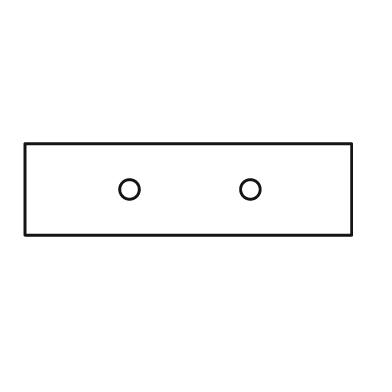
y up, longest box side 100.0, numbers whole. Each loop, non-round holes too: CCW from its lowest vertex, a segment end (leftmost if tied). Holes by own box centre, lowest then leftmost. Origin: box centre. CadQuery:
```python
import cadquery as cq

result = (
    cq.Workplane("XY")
    .moveTo(-50.0, -14.0)
    .lineTo(50.0, -14.0)
    .lineTo(50.0, 14.0)
    .lineTo(-50.0, 14.0)
    .close()
    .moveTo(-18.0, 0.0)
    .circle(3.0)
    .moveTo(19.0, 0.0)
    .circle(3.0)
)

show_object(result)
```